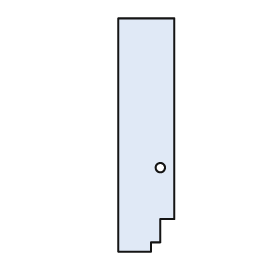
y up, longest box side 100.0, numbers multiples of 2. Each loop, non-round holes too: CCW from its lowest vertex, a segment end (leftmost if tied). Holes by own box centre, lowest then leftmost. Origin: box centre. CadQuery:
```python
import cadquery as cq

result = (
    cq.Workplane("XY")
    .moveTo(-12.0, -50.0)
    .lineTo(2.0, -50.0)
    .lineTo(2.0, -46.0)
    .lineTo(6.0, -46.0)
    .lineTo(6.0, -36.0)
    .lineTo(12.0, -36.0)
    .lineTo(12.0, 50.0)
    .lineTo(-12.0, 50.0)
    .close()
    .moveTo(6.0, -14.0)
    .circle(2.0)
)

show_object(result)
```